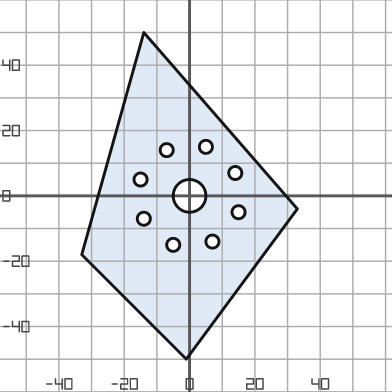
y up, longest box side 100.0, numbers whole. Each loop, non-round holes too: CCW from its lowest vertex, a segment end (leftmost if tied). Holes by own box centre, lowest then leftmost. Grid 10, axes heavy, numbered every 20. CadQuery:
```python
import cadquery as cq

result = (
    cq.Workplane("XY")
    .moveTo(-1.0, -50.0)
    .lineTo(33.0, -4.0)
    .lineTo(-14.0, 50.0)
    .lineTo(-33.0, -18.0)
    .close()
    .moveTo(-5.0, -15.0)
    .circle(2.0)
    .moveTo(7.0, -14.0)
    .circle(2.0)
    .moveTo(-14.0, -7.0)
    .circle(2.0)
    .moveTo(15.0, -5.0)
    .circle(2.0)
    .moveTo(0.0, 0.0)
    .circle(5.0)
    .moveTo(-15.0, 5.0)
    .circle(2.0)
    .moveTo(14.0, 7.0)
    .circle(2.0)
    .moveTo(-7.0, 14.0)
    .circle(2.0)
    .moveTo(5.0, 15.0)
    .circle(2.0)
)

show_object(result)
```